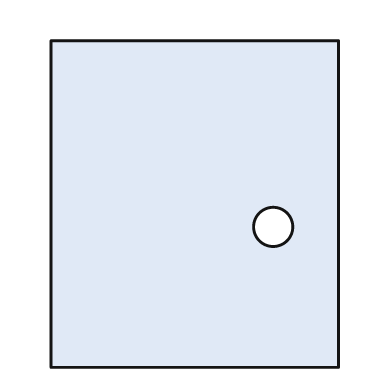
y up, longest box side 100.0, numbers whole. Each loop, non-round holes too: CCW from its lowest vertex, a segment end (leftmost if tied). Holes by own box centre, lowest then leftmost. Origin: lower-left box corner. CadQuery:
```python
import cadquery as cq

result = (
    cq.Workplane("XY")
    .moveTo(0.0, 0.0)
    .lineTo(88.0, 0.0)
    .lineTo(88.0, 100.0)
    .lineTo(0.0, 100.0)
    .close()
    .moveTo(68.0, 43.0)
    .circle(6.0)
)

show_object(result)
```